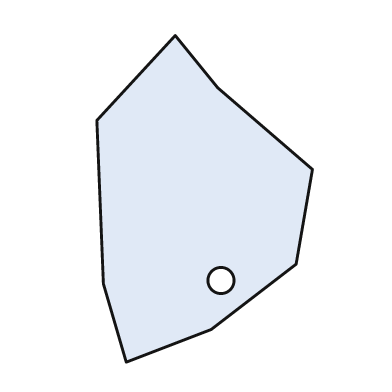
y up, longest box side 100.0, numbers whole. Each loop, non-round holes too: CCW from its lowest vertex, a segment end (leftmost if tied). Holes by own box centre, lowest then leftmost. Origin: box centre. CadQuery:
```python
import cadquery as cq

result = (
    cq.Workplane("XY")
    .moveTo(-24.0, -50.0)
    .lineTo(2.0, -40.0)
    .lineTo(28.0, -20.0)
    .lineTo(33.0, 9.0)
    .lineTo(4.0, 34.0)
    .lineTo(-9.0, 50.0)
    .lineTo(-33.0, 24.0)
    .lineTo(-31.0, -26.0)
    .close()
    .moveTo(5.0, -25.0)
    .circle(4.0)
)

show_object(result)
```